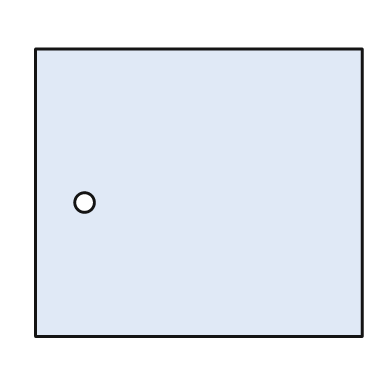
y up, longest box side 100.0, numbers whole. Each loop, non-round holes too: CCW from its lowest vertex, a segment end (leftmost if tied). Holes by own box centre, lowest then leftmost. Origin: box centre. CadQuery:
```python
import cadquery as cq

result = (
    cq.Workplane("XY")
    .moveTo(-50.0, -44.0)
    .lineTo(50.0, -44.0)
    .lineTo(50.0, 44.0)
    .lineTo(-50.0, 44.0)
    .close()
    .moveTo(-35.0, -3.0)
    .circle(3.0)
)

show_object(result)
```